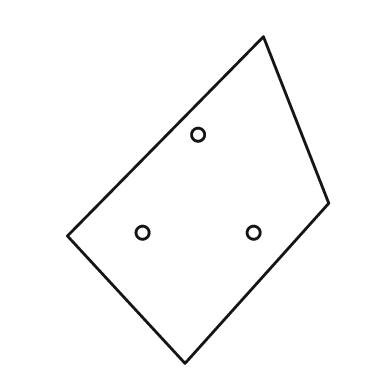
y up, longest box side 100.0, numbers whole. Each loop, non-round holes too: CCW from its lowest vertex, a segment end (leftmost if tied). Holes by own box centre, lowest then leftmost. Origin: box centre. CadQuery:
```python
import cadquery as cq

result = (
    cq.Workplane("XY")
    .moveTo(-4.0, -50.0)
    .lineTo(40.0, -1.0)
    .lineTo(20.0, 50.0)
    .lineTo(-40.0, -11.0)
    .close()
    .moveTo(-17.0, -10.0)
    .circle(2.0)
    .moveTo(17.0, -10.0)
    .circle(2.0)
    .moveTo(0.0, 20.0)
    .circle(2.0)
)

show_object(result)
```